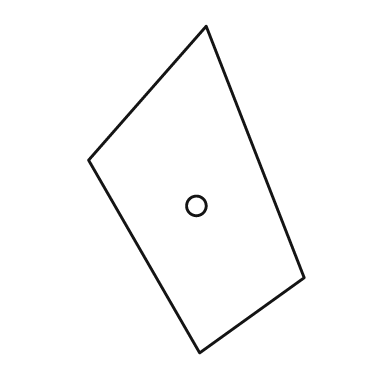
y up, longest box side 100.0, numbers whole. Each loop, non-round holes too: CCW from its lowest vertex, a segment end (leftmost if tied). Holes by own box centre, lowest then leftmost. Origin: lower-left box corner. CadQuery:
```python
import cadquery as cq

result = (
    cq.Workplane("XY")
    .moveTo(34.0, 0.0)
    .lineTo(66.0, 23.0)
    .lineTo(36.0, 100.0)
    .lineTo(0.0, 59.0)
    .close()
    .moveTo(33.0, 45.0)
    .circle(3.0)
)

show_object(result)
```